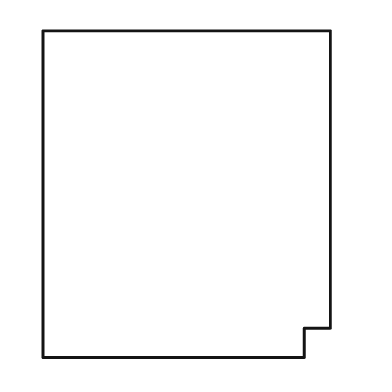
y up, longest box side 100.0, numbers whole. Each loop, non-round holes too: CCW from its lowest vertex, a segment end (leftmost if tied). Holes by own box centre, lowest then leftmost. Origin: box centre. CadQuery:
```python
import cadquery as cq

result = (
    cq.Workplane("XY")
    .moveTo(-44.0, -50.0)
    .lineTo(36.0, -50.0)
    .lineTo(36.0, -41.0)
    .lineTo(44.0, -41.0)
    .lineTo(44.0, 50.0)
    .lineTo(-44.0, 50.0)
    .close()
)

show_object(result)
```